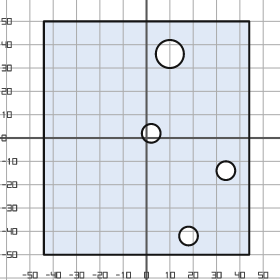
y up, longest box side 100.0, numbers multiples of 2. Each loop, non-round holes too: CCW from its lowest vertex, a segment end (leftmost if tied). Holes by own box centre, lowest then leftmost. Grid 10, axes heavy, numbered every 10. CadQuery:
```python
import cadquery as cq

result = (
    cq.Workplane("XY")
    .moveTo(-44.0, -50.0)
    .lineTo(44.0, -50.0)
    .lineTo(44.0, 50.0)
    .lineTo(-44.0, 50.0)
    .close()
    .moveTo(18.0, -42.0)
    .circle(4.0)
    .moveTo(34.0, -14.0)
    .circle(4.0)
    .moveTo(2.0, 2.0)
    .circle(4.0)
    .moveTo(10.0, 36.0)
    .circle(6.0)
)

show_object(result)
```